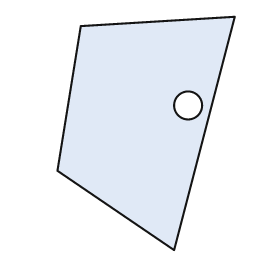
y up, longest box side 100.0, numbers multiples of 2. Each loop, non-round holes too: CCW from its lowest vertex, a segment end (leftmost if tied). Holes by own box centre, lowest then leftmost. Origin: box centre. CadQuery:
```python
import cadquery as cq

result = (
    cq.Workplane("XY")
    .moveTo(12.0, -50.0)
    .lineTo(38.0, 50.0)
    .lineTo(-28.0, 46.0)
    .lineTo(-38.0, -16.0)
    .close()
    .moveTo(18.0, 12.0)
    .circle(6.0)
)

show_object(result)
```